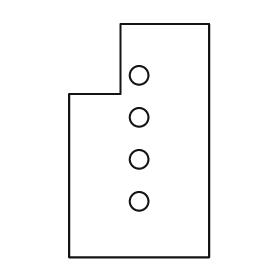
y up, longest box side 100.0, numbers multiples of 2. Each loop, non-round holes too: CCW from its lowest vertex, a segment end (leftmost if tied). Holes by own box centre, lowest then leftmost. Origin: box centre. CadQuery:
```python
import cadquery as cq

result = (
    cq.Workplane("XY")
    .moveTo(-30.0, -50.0)
    .lineTo(30.0, -50.0)
    .lineTo(30.0, 50.0)
    .lineTo(-8.0, 50.0)
    .lineTo(-8.0, 20.0)
    .lineTo(-30.0, 20.0)
    .close()
    .moveTo(0.0, -26.0)
    .circle(4.0)
    .moveTo(0.0, -8.0)
    .circle(4.0)
    .moveTo(0.0, 10.0)
    .circle(4.0)
    .moveTo(0.0, 28.0)
    .circle(4.0)
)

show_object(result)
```